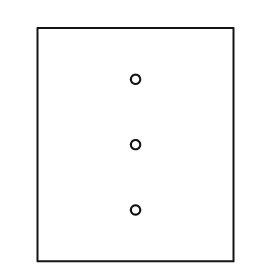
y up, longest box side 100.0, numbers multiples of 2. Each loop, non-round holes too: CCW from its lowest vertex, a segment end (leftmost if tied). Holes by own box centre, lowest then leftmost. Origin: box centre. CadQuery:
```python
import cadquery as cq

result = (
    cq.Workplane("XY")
    .moveTo(-42.0, -50.0)
    .lineTo(42.0, -50.0)
    .lineTo(42.0, 50.0)
    .lineTo(-42.0, 50.0)
    .close()
    .moveTo(0.0, -28.0)
    .circle(2.0)
    .moveTo(0.0, 0.0)
    .circle(2.0)
    .moveTo(0.0, 28.0)
    .circle(2.0)
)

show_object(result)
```